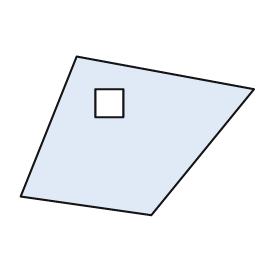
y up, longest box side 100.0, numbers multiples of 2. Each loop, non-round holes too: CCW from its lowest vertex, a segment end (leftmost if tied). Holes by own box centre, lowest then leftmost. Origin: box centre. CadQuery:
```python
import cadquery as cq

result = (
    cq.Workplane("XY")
    .moveTo(6.0, -34.0)
    .lineTo(50.0, 20.0)
    .lineTo(-26.0, 34.0)
    .lineTo(-50.0, -26.0)
    .close()
    .moveTo(-18.0, 8.0)
    .lineTo(-6.0, 8.0)
    .lineTo(-6.0, 20.0)
    .lineTo(-18.0, 20.0)
    .close()
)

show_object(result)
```